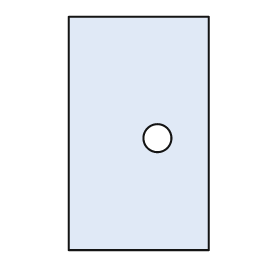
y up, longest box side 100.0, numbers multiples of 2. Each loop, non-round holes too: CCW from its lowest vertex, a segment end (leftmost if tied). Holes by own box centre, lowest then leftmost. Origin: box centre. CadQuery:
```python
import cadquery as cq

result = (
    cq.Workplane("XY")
    .moveTo(-30.0, -50.0)
    .lineTo(30.0, -50.0)
    .lineTo(30.0, 50.0)
    .lineTo(-30.0, 50.0)
    .close()
    .moveTo(8.0, -2.0)
    .circle(6.0)
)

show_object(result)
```